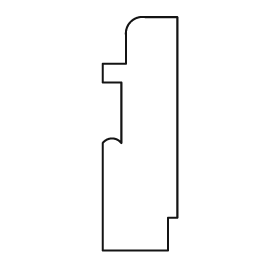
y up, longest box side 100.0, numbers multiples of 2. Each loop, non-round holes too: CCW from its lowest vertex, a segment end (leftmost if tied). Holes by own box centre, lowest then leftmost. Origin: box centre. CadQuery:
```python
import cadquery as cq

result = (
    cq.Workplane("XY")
    .moveTo(-16.0, -50.0)
    .lineTo(12.0, -50.0)
    .lineTo(12.0, -36.0)
    .lineTo(16.0, -36.0)
    .lineTo(16.0, 50.0)
    .lineTo(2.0, 50.0)
    .threePointArc((-4.0, 48.0), (-6.0, 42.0))
    .lineTo(-6.0, 30.0)
    .lineTo(-16.0, 30.0)
    .lineTo(-16.0, 22.0)
    .lineTo(-8.0, 22.0)
    .lineTo(-8.0, -4.0)
    .threePointArc((-12.0, -2.0), (-16.0, -4.0))
    .close()
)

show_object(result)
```